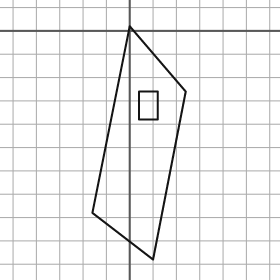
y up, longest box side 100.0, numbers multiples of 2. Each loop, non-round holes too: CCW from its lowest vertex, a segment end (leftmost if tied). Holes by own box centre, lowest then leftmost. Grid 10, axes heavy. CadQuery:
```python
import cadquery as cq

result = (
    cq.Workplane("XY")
    .moveTo(10.0, -98.0)
    .lineTo(24.0, -26.0)
    .lineTo(0.0, 2.0)
    .lineTo(-16.0, -78.0)
    .close()
    .moveTo(4.0, -38.0)
    .lineTo(12.0, -38.0)
    .lineTo(12.0, -26.0)
    .lineTo(4.0, -26.0)
    .close()
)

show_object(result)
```